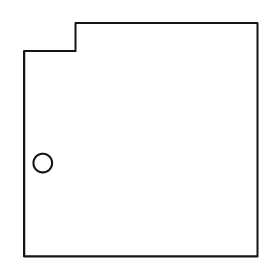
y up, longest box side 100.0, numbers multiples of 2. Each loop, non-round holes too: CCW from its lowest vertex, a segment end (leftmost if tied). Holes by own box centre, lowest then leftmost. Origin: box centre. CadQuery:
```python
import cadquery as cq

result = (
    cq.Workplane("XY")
    .moveTo(-50.0, -50.0)
    .lineTo(50.0, -50.0)
    .lineTo(50.0, 50.0)
    .lineTo(-28.0, 50.0)
    .lineTo(-28.0, 38.0)
    .lineTo(-50.0, 38.0)
    .close()
    .moveTo(-42.0, -10.0)
    .circle(4.0)
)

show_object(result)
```